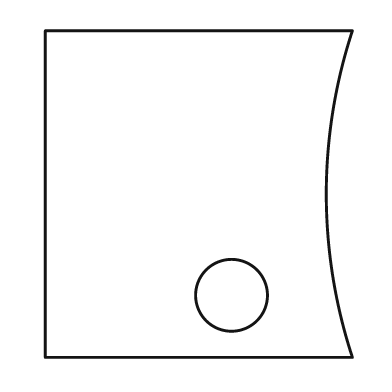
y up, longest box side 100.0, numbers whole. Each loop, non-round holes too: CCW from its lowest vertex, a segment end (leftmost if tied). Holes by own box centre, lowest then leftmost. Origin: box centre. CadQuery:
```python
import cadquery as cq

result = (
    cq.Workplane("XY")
    .moveTo(-47.0, -50.0)
    .lineTo(47.0, -50.0)
    .threePointArc((39.0, 0.0), (47.0, 50.0))
    .lineTo(-47.0, 50.0)
    .close()
    .moveTo(10.0, -31.0)
    .circle(11.0)
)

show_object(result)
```